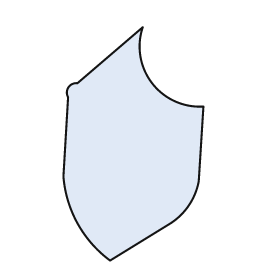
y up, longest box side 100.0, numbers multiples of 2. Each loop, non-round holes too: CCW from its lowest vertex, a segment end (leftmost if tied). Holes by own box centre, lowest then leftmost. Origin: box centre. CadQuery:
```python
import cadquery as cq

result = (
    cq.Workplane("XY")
    .moveTo(-10.0, -50.0)
    .lineTo(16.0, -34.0)
    .threePointArc((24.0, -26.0), (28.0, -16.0))
    .lineTo(30.0, 16.0)
    .threePointArc((8.0, 26.0), (4.0, 50.0))
    .lineTo(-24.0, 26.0)
    .threePointArc((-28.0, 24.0), (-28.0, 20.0))
    .lineTo(-30.0, -14.0)
    .threePointArc((-24.0, -34.0), (-10.0, -50.0))
    .close()
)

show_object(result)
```